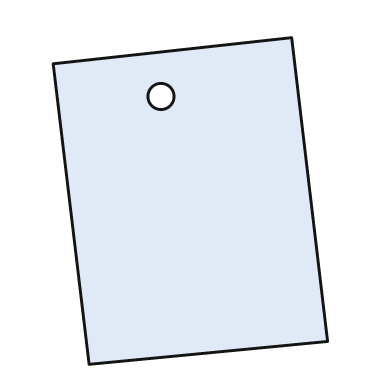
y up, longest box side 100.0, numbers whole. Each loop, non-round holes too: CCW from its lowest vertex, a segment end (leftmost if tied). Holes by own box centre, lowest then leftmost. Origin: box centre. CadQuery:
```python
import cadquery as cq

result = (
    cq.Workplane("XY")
    .moveTo(-31.0, -50.0)
    .lineTo(42.0, -43.0)
    .lineTo(31.0, 50.0)
    .lineTo(-42.0, 42.0)
    .close()
    .moveTo(-9.0, 32.0)
    .circle(4.0)
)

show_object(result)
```